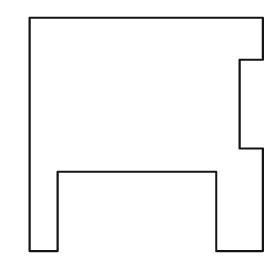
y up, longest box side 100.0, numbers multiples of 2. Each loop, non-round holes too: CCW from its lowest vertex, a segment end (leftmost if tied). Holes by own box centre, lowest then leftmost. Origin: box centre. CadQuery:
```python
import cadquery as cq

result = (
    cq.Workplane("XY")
    .moveTo(-50.0, -50.0)
    .lineTo(-38.0, -50.0)
    .lineTo(-38.0, -16.0)
    .lineTo(30.0, -16.0)
    .lineTo(30.0, -50.0)
    .lineTo(50.0, -50.0)
    .lineTo(50.0, -6.0)
    .lineTo(40.0, -6.0)
    .lineTo(40.0, 32.0)
    .lineTo(50.0, 32.0)
    .lineTo(50.0, 50.0)
    .lineTo(-50.0, 50.0)
    .close()
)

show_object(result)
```